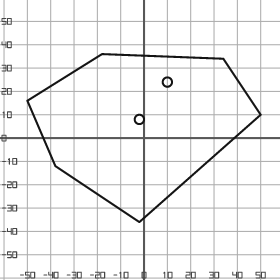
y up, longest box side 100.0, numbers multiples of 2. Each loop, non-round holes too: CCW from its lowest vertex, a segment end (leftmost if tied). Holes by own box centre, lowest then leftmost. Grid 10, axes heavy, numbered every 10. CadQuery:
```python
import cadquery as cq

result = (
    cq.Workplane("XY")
    .moveTo(-2.0, -36.0)
    .lineTo(50.0, 10.0)
    .lineTo(34.0, 34.0)
    .lineTo(-18.0, 36.0)
    .lineTo(-50.0, 16.0)
    .lineTo(-38.0, -12.0)
    .close()
    .moveTo(-2.0, 8.0)
    .circle(2.0)
    .moveTo(10.0, 24.0)
    .circle(2.0)
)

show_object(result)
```